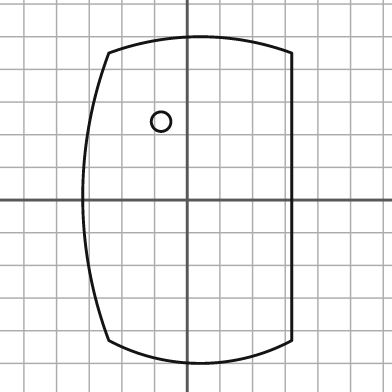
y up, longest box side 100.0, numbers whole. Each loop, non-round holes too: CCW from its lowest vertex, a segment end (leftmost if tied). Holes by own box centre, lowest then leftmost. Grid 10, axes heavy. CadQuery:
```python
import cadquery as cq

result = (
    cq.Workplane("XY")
    .moveTo(-24.0, -43.0)
    .threePointArc((4.0, -50.0), (32.0, -43.0))
    .lineTo(32.0, 45.0)
    .threePointArc((4.0, 50.0), (-24.0, 45.0))
    .threePointArc((-32.0, 1.0), (-24.0, -43.0))
    .close()
    .moveTo(-8.0, 24.0)
    .circle(3.0)
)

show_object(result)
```